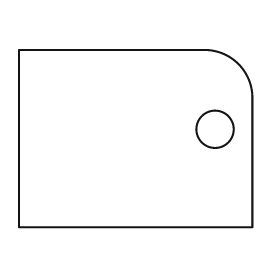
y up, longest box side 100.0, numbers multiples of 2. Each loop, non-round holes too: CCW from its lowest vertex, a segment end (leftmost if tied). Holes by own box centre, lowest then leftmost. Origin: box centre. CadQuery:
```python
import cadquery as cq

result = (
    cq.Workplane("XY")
    .moveTo(-50.0, -38.0)
    .lineTo(50.0, -38.0)
    .lineTo(50.0, 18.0)
    .threePointArc((44.0, 32.0), (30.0, 38.0))
    .lineTo(-50.0, 38.0)
    .close()
    .moveTo(34.0, 4.0)
    .circle(8.0)
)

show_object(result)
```